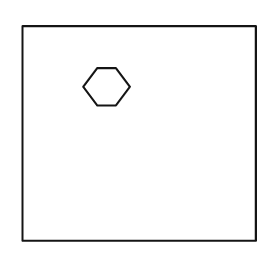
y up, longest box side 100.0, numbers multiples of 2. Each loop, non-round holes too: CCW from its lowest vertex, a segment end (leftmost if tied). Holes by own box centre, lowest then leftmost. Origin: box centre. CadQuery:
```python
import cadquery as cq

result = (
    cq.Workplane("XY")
    .moveTo(-50.0, -46.0)
    .lineTo(50.0, -46.0)
    .lineTo(50.0, 46.0)
    .lineTo(-50.0, 46.0)
    .close()
    .moveTo(-18.0, 12.0)
    .lineTo(-10.0, 12.0)
    .lineTo(-4.0, 20.0)
    .lineTo(-10.0, 28.0)
    .lineTo(-18.0, 28.0)
    .lineTo(-24.0, 20.0)
    .close()
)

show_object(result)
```